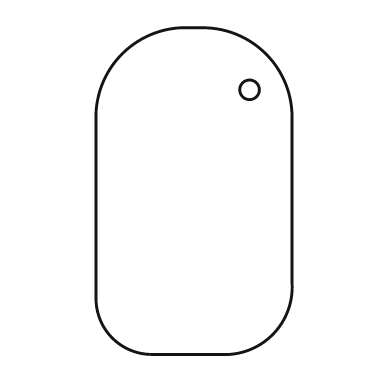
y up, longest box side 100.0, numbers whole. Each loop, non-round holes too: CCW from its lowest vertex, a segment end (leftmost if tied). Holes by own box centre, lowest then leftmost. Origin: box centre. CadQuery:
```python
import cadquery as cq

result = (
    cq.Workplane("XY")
    .moveTo(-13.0, -50.0)
    .lineTo(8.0, -50.0)
    .threePointArc((24.0, -44.0), (30.0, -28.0))
    .lineTo(30.0, 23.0)
    .threePointArc((22.0, 42.0), (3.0, 50.0))
    .lineTo(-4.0, 50.0)
    .threePointArc((-22.0, 42.0), (-30.0, 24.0))
    .lineTo(-30.0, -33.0)
    .threePointArc((-25.0, -45.0), (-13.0, -50.0))
    .close()
    .moveTo(17.0, 31.0)
    .circle(3.0)
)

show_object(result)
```